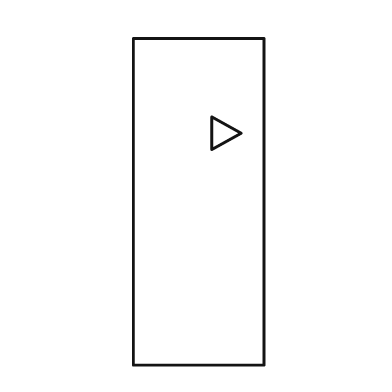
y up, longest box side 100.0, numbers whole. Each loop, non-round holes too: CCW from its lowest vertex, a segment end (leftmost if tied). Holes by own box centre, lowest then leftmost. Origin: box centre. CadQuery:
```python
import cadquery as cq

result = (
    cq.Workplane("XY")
    .moveTo(-20.0, -50.0)
    .lineTo(20.0, -50.0)
    .lineTo(20.0, 50.0)
    .lineTo(-20.0, 50.0)
    .close()
    .moveTo(4.0, 16.0)
    .lineTo(13.0, 21.0)
    .lineTo(4.0, 26.0)
    .close()
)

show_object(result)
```